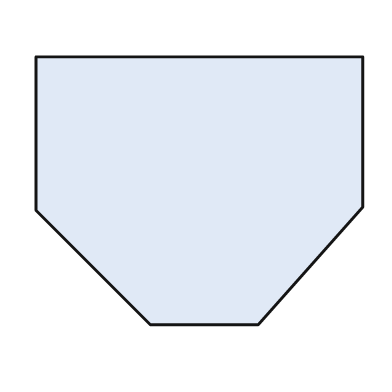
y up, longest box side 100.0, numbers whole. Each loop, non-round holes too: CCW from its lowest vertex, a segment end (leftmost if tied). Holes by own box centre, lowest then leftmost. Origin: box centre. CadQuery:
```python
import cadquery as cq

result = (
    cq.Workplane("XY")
    .moveTo(-15.0, -41.0)
    .lineTo(18.0, -41.0)
    .lineTo(50.0, -5.0)
    .lineTo(50.0, 41.0)
    .lineTo(-50.0, 41.0)
    .lineTo(-50.0, -6.0)
    .close()
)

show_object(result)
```